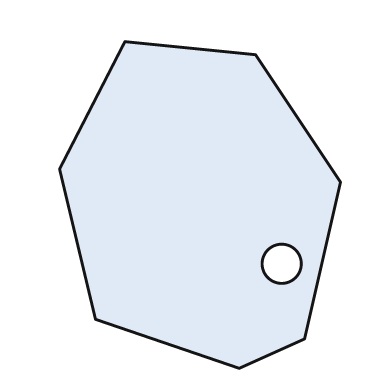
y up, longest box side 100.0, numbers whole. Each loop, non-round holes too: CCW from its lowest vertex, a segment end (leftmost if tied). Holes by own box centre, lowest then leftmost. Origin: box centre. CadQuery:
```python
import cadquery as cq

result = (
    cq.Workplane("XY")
    .moveTo(12.0, -50.0)
    .lineTo(32.0, -41.0)
    .lineTo(43.0, 7.0)
    .lineTo(17.0, 46.0)
    .lineTo(-23.0, 50.0)
    .lineTo(-43.0, 11.0)
    .lineTo(-32.0, -35.0)
    .close()
    .moveTo(25.0, -18.0)
    .circle(6.0)
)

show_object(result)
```